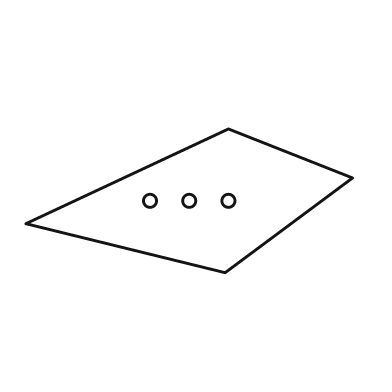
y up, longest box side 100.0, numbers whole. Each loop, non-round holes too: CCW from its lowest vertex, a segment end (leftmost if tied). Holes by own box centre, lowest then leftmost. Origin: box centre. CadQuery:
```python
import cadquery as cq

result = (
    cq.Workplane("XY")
    .moveTo(11.0, -22.0)
    .lineTo(50.0, 7.0)
    .lineTo(12.0, 22.0)
    .lineTo(-50.0, -7.0)
    .close()
    .moveTo(-12.0, 0.0)
    .circle(2.0)
    .moveTo(0.0, 0.0)
    .circle(2.0)
    .moveTo(12.0, 0.0)
    .circle(2.0)
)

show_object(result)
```